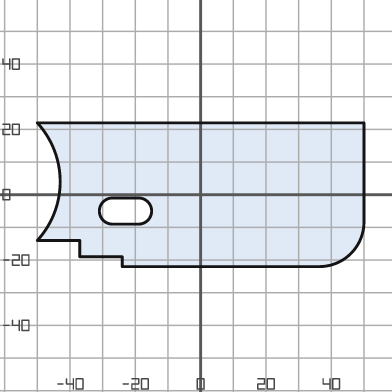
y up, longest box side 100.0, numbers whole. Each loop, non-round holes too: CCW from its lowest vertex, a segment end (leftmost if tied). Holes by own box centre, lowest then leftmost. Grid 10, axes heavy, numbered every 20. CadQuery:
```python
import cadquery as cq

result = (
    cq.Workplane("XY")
    .moveTo(-24.0, -22.0)
    .lineTo(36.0, -22.0)
    .threePointArc((46.0, -18.0), (50.0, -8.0))
    .lineTo(50.0, 22.0)
    .lineTo(-50.0, 22.0)
    .threePointArc((-43.0, 4.0), (-50.0, -14.0))
    .lineTo(-37.0, -14.0)
    .lineTo(-37.0, -19.0)
    .lineTo(-24.0, -19.0)
    .close()
    .moveTo(-27.0, -9.0)
    .lineTo(-19.0, -9.0)
    .threePointArc((-15.0, -5.0), (-19.0, -1.0))
    .lineTo(-27.0, -1.0)
    .threePointArc((-31.0, -5.0), (-27.0, -9.0))
    .close()
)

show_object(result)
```